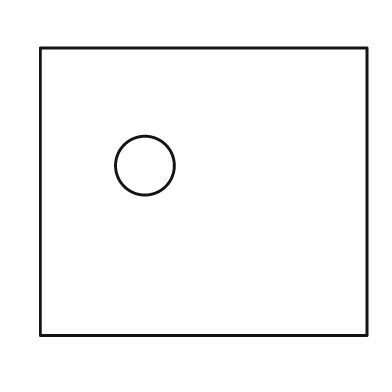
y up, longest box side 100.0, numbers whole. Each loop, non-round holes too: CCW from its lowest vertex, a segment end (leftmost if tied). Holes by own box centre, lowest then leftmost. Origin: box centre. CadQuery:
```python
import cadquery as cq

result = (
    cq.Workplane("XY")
    .moveTo(-50.0, -44.0)
    .lineTo(50.0, -44.0)
    .lineTo(50.0, 44.0)
    .lineTo(-50.0, 44.0)
    .close()
    .moveTo(-18.0, 8.0)
    .circle(9.0)
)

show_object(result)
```